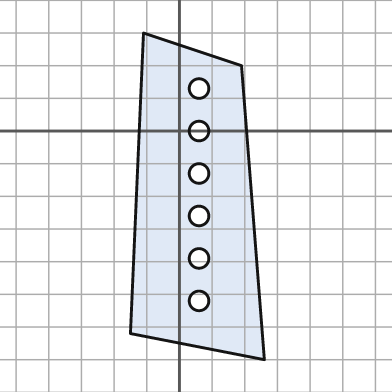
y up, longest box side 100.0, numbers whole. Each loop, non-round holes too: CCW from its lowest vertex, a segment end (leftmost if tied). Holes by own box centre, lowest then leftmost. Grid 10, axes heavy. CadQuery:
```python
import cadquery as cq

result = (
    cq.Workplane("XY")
    .moveTo(26.0, -70.0)
    .lineTo(19.0, 20.0)
    .lineTo(-11.0, 30.0)
    .lineTo(-15.0, -62.0)
    .close()
    .moveTo(6.0, -52.0)
    .circle(3.0)
    .moveTo(6.0, -39.0)
    .circle(3.0)
    .moveTo(6.0, -26.0)
    .circle(3.0)
    .moveTo(6.0, -13.0)
    .circle(3.0)
    .moveTo(6.0, 0.0)
    .circle(3.0)
    .moveTo(6.0, 13.0)
    .circle(3.0)
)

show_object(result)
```